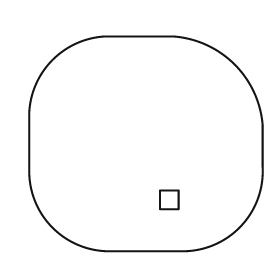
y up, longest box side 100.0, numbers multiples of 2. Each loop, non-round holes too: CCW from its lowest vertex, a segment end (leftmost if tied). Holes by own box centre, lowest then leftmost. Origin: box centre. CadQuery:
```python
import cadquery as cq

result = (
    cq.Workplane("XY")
    .moveTo(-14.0, -46.0)
    .lineTo(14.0, -46.0)
    .threePointArc((40.0, -36.0), (50.0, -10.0))
    .lineTo(50.0, 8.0)
    .threePointArc((38.0, 34.0), (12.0, 46.0))
    .lineTo(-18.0, 46.0)
    .threePointArc((-40.0, 36.0), (-50.0, 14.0))
    .lineTo(-50.0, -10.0)
    .threePointArc((-40.0, -36.0), (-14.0, -46.0))
    .close()
    .moveTo(6.0, -28.0)
    .lineTo(14.0, -28.0)
    .lineTo(14.0, -20.0)
    .lineTo(6.0, -20.0)
    .close()
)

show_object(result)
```